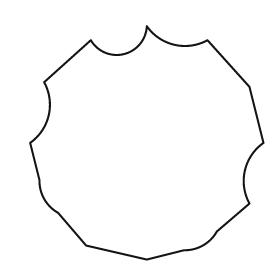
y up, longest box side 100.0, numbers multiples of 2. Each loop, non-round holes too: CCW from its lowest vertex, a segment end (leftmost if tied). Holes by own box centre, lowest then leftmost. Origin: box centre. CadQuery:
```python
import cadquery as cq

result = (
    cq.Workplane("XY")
    .moveTo(0.0, -50.0)
    .lineTo(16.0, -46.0)
    .threePointArc((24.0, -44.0), (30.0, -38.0))
    .lineTo(44.0, -26.0)
    .threePointArc((42.0, -12.0), (50.0, 0.0))
    .lineTo(44.0, 24.0)
    .lineTo(26.0, 44.0)
    .threePointArc((12.0, 42.0), (0.0, 50.0))
    .threePointArc((-10.0, 38.0), (-24.0, 44.0))
    .lineTo(-44.0, 26.0)
    .threePointArc((-42.0, 12.0), (-50.0, 0.0))
    .lineTo(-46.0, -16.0)
    .threePointArc((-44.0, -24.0), (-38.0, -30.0))
    .lineTo(-26.0, -44.0)
    .close()
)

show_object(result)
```